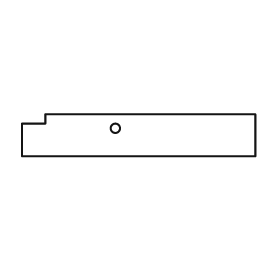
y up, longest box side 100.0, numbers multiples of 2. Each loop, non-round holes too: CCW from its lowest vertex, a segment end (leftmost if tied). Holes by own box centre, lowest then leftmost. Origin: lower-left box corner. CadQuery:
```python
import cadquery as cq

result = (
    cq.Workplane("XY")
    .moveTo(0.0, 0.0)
    .lineTo(100.0, 0.0)
    .lineTo(100.0, 18.0)
    .lineTo(10.0, 18.0)
    .lineTo(10.0, 14.0)
    .lineTo(0.0, 14.0)
    .close()
    .moveTo(40.0, 12.0)
    .circle(2.0)
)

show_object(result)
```